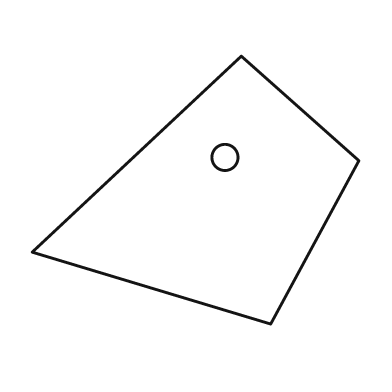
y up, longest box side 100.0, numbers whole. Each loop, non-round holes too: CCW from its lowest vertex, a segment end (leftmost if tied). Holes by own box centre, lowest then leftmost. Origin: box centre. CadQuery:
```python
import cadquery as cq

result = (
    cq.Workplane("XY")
    .moveTo(23.0, -41.0)
    .lineTo(50.0, 9.0)
    .lineTo(14.0, 41.0)
    .lineTo(-50.0, -19.0)
    .close()
    .moveTo(9.0, 10.0)
    .circle(4.0)
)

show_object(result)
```